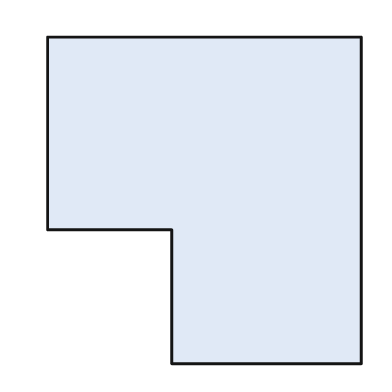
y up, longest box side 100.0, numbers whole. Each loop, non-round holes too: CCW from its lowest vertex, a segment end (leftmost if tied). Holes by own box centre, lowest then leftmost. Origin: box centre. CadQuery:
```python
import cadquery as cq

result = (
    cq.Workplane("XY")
    .moveTo(-10.0, -50.0)
    .lineTo(48.0, -50.0)
    .lineTo(48.0, 50.0)
    .lineTo(-48.0, 50.0)
    .lineTo(-48.0, -9.0)
    .lineTo(-10.0, -9.0)
    .close()
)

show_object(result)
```